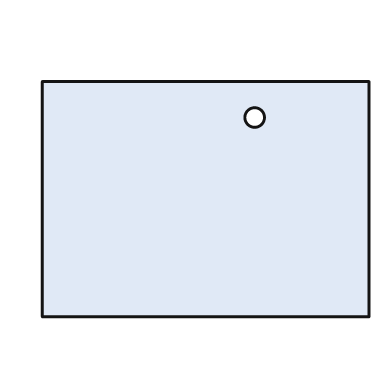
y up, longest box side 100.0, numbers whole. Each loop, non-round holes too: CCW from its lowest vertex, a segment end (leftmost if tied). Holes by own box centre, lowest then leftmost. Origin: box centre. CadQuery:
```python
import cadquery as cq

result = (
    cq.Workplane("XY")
    .moveTo(-50.0, -36.0)
    .lineTo(50.0, -36.0)
    .lineTo(50.0, 36.0)
    .lineTo(-50.0, 36.0)
    .close()
    .moveTo(15.0, 25.0)
    .circle(3.0)
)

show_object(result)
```